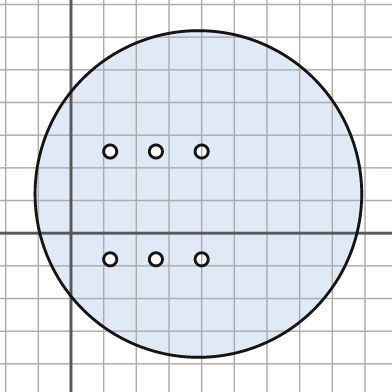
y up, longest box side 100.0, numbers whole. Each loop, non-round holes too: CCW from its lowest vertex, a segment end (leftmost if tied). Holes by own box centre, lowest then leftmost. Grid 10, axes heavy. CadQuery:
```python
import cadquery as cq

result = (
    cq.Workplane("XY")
    .moveTo(39.0, 12.0)
    .circle(50.0)
    .moveTo(12.0, -8.0)
    .circle(2.0)
    .moveTo(26.0, -8.0)
    .circle(2.0)
    .moveTo(40.0, -8.0)
    .circle(2.0)
    .moveTo(12.0, 25.0)
    .circle(2.0)
    .moveTo(26.0, 25.0)
    .circle(2.0)
    .moveTo(40.0, 25.0)
    .circle(2.0)
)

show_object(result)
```